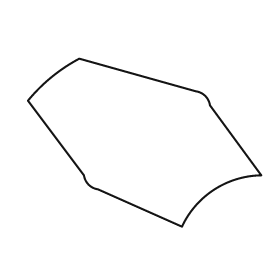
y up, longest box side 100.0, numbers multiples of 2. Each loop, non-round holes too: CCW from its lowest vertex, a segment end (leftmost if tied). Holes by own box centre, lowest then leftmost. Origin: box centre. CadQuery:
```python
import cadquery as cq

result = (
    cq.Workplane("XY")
    .moveTo(16.0, -36.0)
    .threePointArc((30.0, -20.0), (50.0, -14.0))
    .lineTo(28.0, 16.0)
    .threePointArc((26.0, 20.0), (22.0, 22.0))
    .lineTo(-28.0, 36.0)
    .threePointArc((-40.0, 28.0), (-50.0, 18.0))
    .lineTo(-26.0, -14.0)
    .threePointArc((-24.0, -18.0), (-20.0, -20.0))
    .close()
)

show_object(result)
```